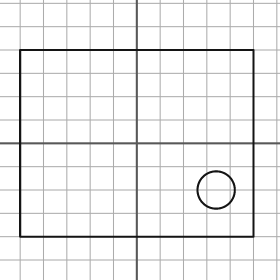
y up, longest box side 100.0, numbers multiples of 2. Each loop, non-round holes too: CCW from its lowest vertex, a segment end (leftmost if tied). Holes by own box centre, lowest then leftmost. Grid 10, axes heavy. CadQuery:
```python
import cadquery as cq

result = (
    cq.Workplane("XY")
    .moveTo(-50.0, -40.0)
    .lineTo(50.0, -40.0)
    .lineTo(50.0, 40.0)
    .lineTo(-50.0, 40.0)
    .close()
    .moveTo(34.0, -20.0)
    .circle(8.0)
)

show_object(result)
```